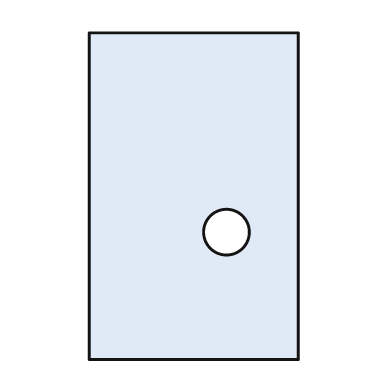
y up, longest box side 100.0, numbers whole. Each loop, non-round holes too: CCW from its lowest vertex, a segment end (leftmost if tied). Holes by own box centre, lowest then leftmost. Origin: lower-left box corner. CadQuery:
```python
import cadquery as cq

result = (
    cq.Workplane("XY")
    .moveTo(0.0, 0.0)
    .lineTo(64.0, 0.0)
    .lineTo(64.0, 100.0)
    .lineTo(0.0, 100.0)
    .close()
    .moveTo(42.0, 39.0)
    .circle(7.0)
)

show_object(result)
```